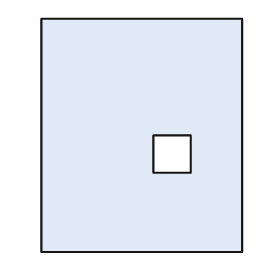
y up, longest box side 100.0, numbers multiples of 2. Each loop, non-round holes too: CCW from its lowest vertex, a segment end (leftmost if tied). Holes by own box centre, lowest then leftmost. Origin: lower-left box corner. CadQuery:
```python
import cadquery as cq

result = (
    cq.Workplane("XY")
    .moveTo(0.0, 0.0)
    .lineTo(86.0, 0.0)
    .lineTo(86.0, 100.0)
    .lineTo(0.0, 100.0)
    .close()
    .moveTo(48.0, 34.0)
    .lineTo(64.0, 34.0)
    .lineTo(64.0, 50.0)
    .lineTo(48.0, 50.0)
    .close()
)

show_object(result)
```